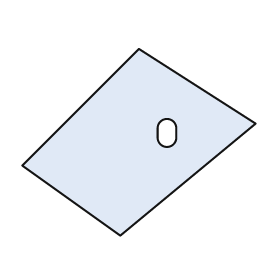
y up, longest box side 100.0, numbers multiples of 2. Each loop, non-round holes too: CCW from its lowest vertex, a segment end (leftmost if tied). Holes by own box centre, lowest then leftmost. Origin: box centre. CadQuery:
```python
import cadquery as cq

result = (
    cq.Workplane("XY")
    .moveTo(-8.0, -40.0)
    .lineTo(50.0, 8.0)
    .lineTo(0.0, 40.0)
    .lineTo(-50.0, -10.0)
    .close()
    .moveTo(8.0, 2.0)
    .threePointArc((12.0, -2.0), (16.0, 2.0))
    .lineTo(16.0, 6.0)
    .threePointArc((12.0, 10.0), (8.0, 6.0))
    .close()
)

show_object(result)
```